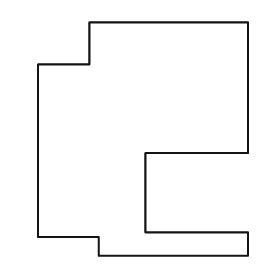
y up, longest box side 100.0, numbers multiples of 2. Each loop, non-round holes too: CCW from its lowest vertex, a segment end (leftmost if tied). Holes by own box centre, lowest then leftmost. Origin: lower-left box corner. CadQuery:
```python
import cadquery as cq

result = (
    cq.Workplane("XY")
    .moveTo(26.0, 0.0)
    .lineTo(90.0, 0.0)
    .lineTo(90.0, 10.0)
    .lineTo(46.0, 10.0)
    .lineTo(46.0, 44.0)
    .lineTo(90.0, 44.0)
    .lineTo(90.0, 100.0)
    .lineTo(22.0, 100.0)
    .lineTo(22.0, 82.0)
    .lineTo(0.0, 82.0)
    .lineTo(0.0, 8.0)
    .lineTo(26.0, 8.0)
    .close()
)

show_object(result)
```